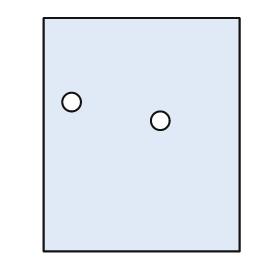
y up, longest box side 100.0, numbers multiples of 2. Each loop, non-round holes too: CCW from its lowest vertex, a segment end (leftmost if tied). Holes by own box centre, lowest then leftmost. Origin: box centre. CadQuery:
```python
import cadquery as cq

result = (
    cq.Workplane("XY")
    .moveTo(-42.0, -50.0)
    .lineTo(42.0, -50.0)
    .lineTo(42.0, 50.0)
    .lineTo(-42.0, 50.0)
    .close()
    .moveTo(8.0, 6.0)
    .circle(4.0)
    .moveTo(-30.0, 14.0)
    .circle(4.0)
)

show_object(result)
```